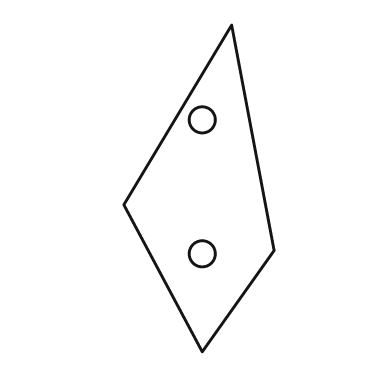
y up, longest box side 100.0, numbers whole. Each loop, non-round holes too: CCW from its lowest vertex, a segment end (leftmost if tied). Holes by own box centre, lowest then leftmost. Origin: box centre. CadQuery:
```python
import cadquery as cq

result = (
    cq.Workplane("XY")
    .moveTo(1.0, -50.0)
    .lineTo(23.0, -19.0)
    .lineTo(10.0, 50.0)
    .lineTo(-23.0, -5.0)
    .close()
    .moveTo(1.0, -20.0)
    .circle(4.0)
    .moveTo(1.0, 21.0)
    .circle(4.0)
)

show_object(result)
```